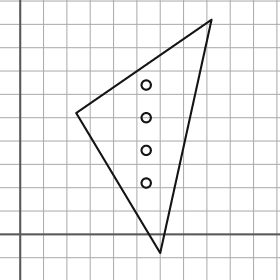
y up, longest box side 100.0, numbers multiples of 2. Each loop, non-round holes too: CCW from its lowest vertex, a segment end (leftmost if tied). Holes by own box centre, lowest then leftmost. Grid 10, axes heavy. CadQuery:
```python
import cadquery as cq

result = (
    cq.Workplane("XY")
    .moveTo(60.0, -8.0)
    .lineTo(82.0, 92.0)
    .lineTo(24.0, 52.0)
    .close()
    .moveTo(54.0, 22.0)
    .circle(2.0)
    .moveTo(54.0, 36.0)
    .circle(2.0)
    .moveTo(54.0, 50.0)
    .circle(2.0)
    .moveTo(54.0, 64.0)
    .circle(2.0)
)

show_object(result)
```